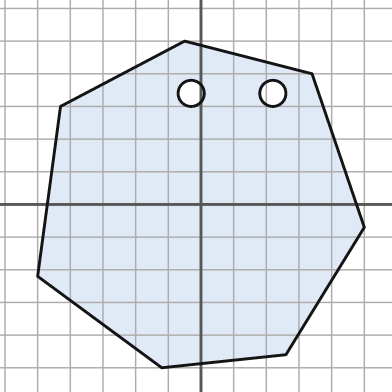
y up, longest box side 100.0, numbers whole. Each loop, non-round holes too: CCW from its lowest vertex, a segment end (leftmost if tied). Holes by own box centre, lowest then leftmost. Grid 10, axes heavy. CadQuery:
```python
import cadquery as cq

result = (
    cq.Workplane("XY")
    .moveTo(-12.0, -50.0)
    .lineTo(26.0, -46.0)
    .lineTo(50.0, -7.0)
    .lineTo(34.0, 40.0)
    .lineTo(-5.0, 50.0)
    .lineTo(-43.0, 30.0)
    .lineTo(-50.0, -22.0)
    .close()
    .moveTo(-3.0, 34.0)
    .circle(4.0)
    .moveTo(22.0, 34.0)
    .circle(4.0)
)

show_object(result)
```